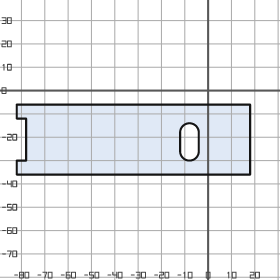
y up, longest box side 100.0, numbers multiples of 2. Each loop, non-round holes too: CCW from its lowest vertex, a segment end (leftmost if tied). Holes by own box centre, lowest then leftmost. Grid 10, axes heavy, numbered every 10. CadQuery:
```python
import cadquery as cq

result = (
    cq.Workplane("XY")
    .moveTo(-82.0, -36.0)
    .lineTo(18.0, -36.0)
    .lineTo(18.0, -6.0)
    .lineTo(-82.0, -6.0)
    .lineTo(-82.0, -12.0)
    .lineTo(-78.0, -12.0)
    .lineTo(-78.0, -30.0)
    .lineTo(-82.0, -30.0)
    .close()
    .moveTo(-12.0, -26.0)
    .threePointArc((-8.0, -30.0), (-4.0, -26.0))
    .lineTo(-4.0, -18.0)
    .threePointArc((-8.0, -14.0), (-12.0, -18.0))
    .close()
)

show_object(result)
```